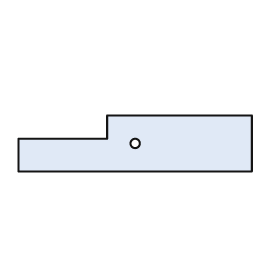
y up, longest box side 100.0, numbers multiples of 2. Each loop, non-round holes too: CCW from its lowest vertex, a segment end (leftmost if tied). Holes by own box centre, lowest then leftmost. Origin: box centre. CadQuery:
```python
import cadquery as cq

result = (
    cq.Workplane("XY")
    .moveTo(-50.0, -12.0)
    .lineTo(50.0, -12.0)
    .lineTo(50.0, 12.0)
    .lineTo(-12.0, 12.0)
    .lineTo(-12.0, 2.0)
    .lineTo(-50.0, 2.0)
    .close()
    .moveTo(0.0, 0.0)
    .circle(2.0)
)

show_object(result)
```